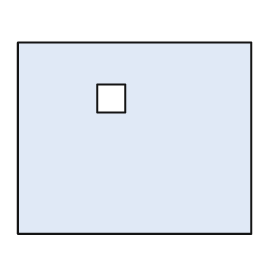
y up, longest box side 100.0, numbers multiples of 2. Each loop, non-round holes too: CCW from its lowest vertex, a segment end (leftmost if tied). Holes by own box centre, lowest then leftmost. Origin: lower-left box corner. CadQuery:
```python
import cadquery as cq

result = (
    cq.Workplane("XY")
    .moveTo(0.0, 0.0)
    .lineTo(100.0, 0.0)
    .lineTo(100.0, 82.0)
    .lineTo(0.0, 82.0)
    .close()
    .moveTo(34.0, 52.0)
    .lineTo(46.0, 52.0)
    .lineTo(46.0, 64.0)
    .lineTo(34.0, 64.0)
    .close()
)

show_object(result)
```